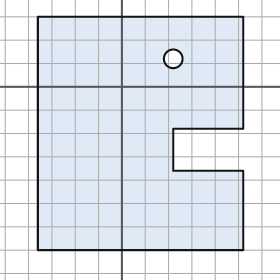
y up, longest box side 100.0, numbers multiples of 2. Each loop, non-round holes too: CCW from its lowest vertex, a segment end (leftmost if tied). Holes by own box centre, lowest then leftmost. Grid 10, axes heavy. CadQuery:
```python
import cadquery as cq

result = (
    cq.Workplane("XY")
    .moveTo(-36.0, -70.0)
    .lineTo(52.0, -70.0)
    .lineTo(52.0, -36.0)
    .lineTo(22.0, -36.0)
    .lineTo(22.0, -18.0)
    .lineTo(52.0, -18.0)
    .lineTo(52.0, 30.0)
    .lineTo(-36.0, 30.0)
    .close()
    .moveTo(22.0, 12.0)
    .circle(4.0)
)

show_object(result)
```